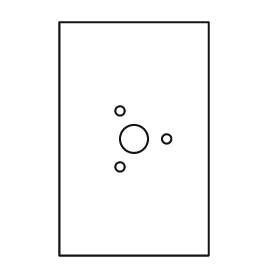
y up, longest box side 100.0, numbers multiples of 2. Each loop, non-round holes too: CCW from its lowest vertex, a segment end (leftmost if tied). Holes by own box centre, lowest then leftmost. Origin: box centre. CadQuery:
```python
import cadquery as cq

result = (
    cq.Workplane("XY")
    .moveTo(-32.0, -50.0)
    .lineTo(32.0, -50.0)
    .lineTo(32.0, 50.0)
    .lineTo(-32.0, 50.0)
    .close()
    .moveTo(-6.0, -12.0)
    .circle(2.0)
    .moveTo(0.0, 0.0)
    .circle(6.0)
    .moveTo(14.0, 0.0)
    .circle(2.0)
    .moveTo(-6.0, 12.0)
    .circle(2.0)
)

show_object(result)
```